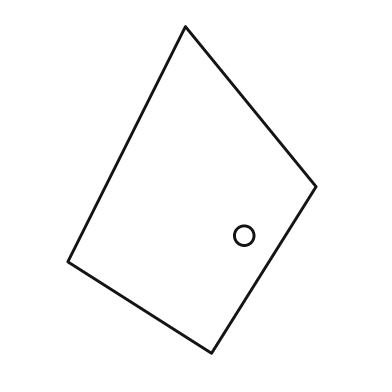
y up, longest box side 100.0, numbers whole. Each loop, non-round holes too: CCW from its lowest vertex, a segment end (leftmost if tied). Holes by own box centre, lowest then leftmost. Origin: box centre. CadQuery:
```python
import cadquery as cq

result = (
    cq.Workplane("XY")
    .moveTo(6.0, -50.0)
    .lineTo(38.0, 1.0)
    .lineTo(-2.0, 50.0)
    .lineTo(-38.0, -22.0)
    .close()
    .moveTo(16.0, -14.0)
    .circle(3.0)
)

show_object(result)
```